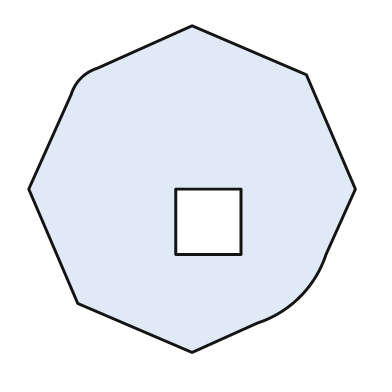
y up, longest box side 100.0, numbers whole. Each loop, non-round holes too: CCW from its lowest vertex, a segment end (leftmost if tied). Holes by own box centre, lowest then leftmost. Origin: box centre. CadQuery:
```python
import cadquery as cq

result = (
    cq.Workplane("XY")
    .moveTo(0.0, -50.0)
    .lineTo(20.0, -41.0)
    .threePointArc((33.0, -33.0), (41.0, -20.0))
    .lineTo(50.0, 0.0)
    .lineTo(35.0, 35.0)
    .lineTo(0.0, 50.0)
    .lineTo(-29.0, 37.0)
    .threePointArc((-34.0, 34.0), (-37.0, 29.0))
    .lineTo(-50.0, 0.0)
    .lineTo(-35.0, -35.0)
    .close()
    .moveTo(-5.0, -20.0)
    .lineTo(15.0, -20.0)
    .lineTo(15.0, 0.0)
    .lineTo(-5.0, 0.0)
    .close()
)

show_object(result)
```